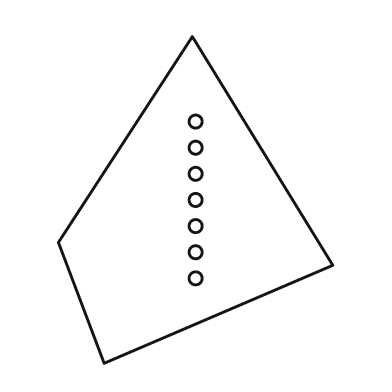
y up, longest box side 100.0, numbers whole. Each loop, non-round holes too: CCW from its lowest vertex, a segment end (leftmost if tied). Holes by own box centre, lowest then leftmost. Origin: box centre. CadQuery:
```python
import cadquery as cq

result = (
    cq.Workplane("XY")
    .moveTo(-28.0, -50.0)
    .lineTo(42.0, -20.0)
    .lineTo(-1.0, 50.0)
    .lineTo(-42.0, -13.0)
    .close()
    .moveTo(0.0, -24.0)
    .circle(2.0)
    .moveTo(0.0, -16.0)
    .circle(2.0)
    .moveTo(0.0, -8.0)
    .circle(2.0)
    .moveTo(0.0, 0.0)
    .circle(2.0)
    .moveTo(0.0, 8.0)
    .circle(2.0)
    .moveTo(0.0, 16.0)
    .circle(2.0)
    .moveTo(0.0, 24.0)
    .circle(2.0)
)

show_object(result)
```